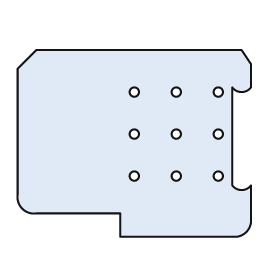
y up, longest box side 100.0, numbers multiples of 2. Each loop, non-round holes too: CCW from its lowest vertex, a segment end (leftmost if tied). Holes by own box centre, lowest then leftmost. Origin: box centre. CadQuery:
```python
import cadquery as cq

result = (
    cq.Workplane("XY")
    .moveTo(-6.0, -40.0)
    .lineTo(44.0, -40.0)
    .threePointArc((48.0, -38.0), (50.0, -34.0))
    .lineTo(50.0, -18.0)
    .threePointArc((46.0, -20.0), (42.0, -18.0))
    .lineTo(42.0, 24.0)
    .threePointArc((46.0, 22.0), (50.0, 24.0))
    .lineTo(50.0, 34.0)
    .lineTo(46.0, 40.0)
    .lineTo(-42.0, 40.0)
    .lineTo(-50.0, 32.0)
    .lineTo(-50.0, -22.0)
    .threePointArc((-48.0, -28.0), (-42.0, -30.0))
    .lineTo(-6.0, -30.0)
    .close()
    .moveTo(0.0, -14.0)
    .circle(2.0)
    .moveTo(18.0, -14.0)
    .circle(2.0)
    .moveTo(36.0, -14.0)
    .circle(2.0)
    .moveTo(0.0, 4.0)
    .circle(2.0)
    .moveTo(18.0, 4.0)
    .circle(2.0)
    .moveTo(36.0, 4.0)
    .circle(2.0)
    .moveTo(0.0, 22.0)
    .circle(2.0)
    .moveTo(18.0, 22.0)
    .circle(2.0)
    .moveTo(36.0, 22.0)
    .circle(2.0)
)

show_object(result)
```